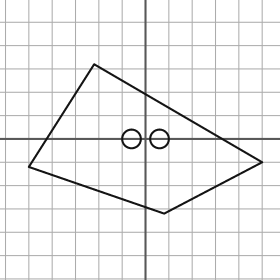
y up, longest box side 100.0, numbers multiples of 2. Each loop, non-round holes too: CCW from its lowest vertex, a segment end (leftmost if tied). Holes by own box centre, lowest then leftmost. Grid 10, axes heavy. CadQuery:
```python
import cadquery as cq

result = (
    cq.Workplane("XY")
    .moveTo(8.0, -32.0)
    .lineTo(50.0, -10.0)
    .lineTo(-22.0, 32.0)
    .lineTo(-50.0, -12.0)
    .close()
    .moveTo(-6.0, 0.0)
    .circle(4.0)
    .moveTo(6.0, 0.0)
    .circle(4.0)
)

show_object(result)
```